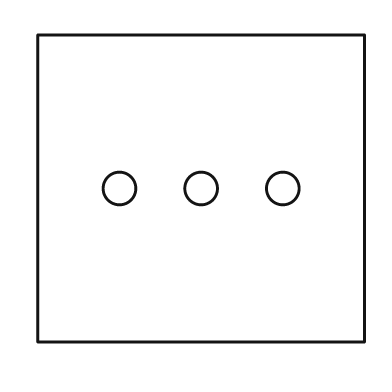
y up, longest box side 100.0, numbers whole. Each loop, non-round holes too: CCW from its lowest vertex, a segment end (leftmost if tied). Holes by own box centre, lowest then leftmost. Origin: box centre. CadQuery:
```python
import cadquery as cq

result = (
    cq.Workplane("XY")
    .moveTo(-50.0, -47.0)
    .lineTo(50.0, -47.0)
    .lineTo(50.0, 47.0)
    .lineTo(-50.0, 47.0)
    .close()
    .moveTo(-25.0, 0.0)
    .circle(5.0)
    .moveTo(0.0, 0.0)
    .circle(5.0)
    .moveTo(25.0, 0.0)
    .circle(5.0)
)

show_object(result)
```